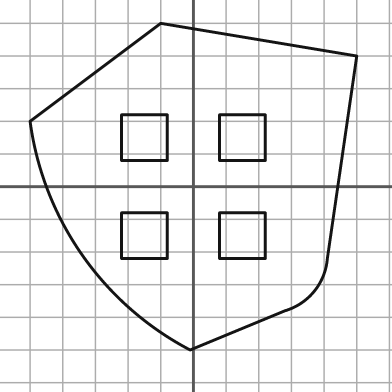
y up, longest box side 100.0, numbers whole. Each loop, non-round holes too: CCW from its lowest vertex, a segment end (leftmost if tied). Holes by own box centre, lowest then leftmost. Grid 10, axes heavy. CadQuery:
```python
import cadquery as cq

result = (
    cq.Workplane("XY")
    .moveTo(-1.0, -50.0)
    .lineTo(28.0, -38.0)
    .threePointArc((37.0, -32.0), (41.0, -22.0))
    .lineTo(50.0, 40.0)
    .lineTo(-10.0, 50.0)
    .lineTo(-50.0, 20.0)
    .threePointArc((-34.0, -21.0), (-1.0, -50.0))
    .close()
    .moveTo(-22.0, -22.0)
    .lineTo(-8.0, -22.0)
    .lineTo(-8.0, -8.0)
    .lineTo(-22.0, -8.0)
    .close()
    .moveTo(8.0, -22.0)
    .lineTo(22.0, -22.0)
    .lineTo(22.0, -8.0)
    .lineTo(8.0, -8.0)
    .close()
    .moveTo(-22.0, 8.0)
    .lineTo(-8.0, 8.0)
    .lineTo(-8.0, 22.0)
    .lineTo(-22.0, 22.0)
    .close()
    .moveTo(8.0, 8.0)
    .lineTo(22.0, 8.0)
    .lineTo(22.0, 22.0)
    .lineTo(8.0, 22.0)
    .close()
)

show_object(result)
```